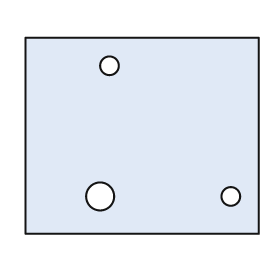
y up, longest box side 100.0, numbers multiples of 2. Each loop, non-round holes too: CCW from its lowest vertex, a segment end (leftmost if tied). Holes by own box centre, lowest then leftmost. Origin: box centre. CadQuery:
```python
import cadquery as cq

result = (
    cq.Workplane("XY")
    .moveTo(-50.0, -42.0)
    .lineTo(50.0, -42.0)
    .lineTo(50.0, 42.0)
    .lineTo(-50.0, 42.0)
    .close()
    .moveTo(-18.0, -26.0)
    .circle(6.0)
    .moveTo(38.0, -26.0)
    .circle(4.0)
    .moveTo(-14.0, 30.0)
    .circle(4.0)
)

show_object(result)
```